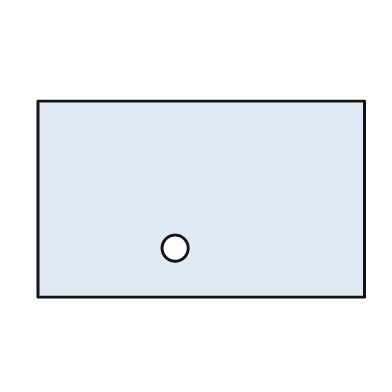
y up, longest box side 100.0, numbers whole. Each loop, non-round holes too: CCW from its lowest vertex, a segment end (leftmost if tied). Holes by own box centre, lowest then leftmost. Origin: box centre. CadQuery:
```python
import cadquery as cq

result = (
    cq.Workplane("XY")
    .moveTo(-50.0, -30.0)
    .lineTo(50.0, -30.0)
    .lineTo(50.0, 30.0)
    .lineTo(-50.0, 30.0)
    .close()
    .moveTo(-8.0, -15.0)
    .circle(4.0)
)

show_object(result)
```